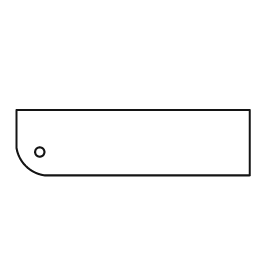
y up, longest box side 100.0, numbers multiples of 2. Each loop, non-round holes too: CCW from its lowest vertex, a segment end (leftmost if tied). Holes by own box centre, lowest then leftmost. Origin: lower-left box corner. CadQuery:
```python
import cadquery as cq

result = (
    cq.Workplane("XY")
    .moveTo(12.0, 0.0)
    .lineTo(100.0, 0.0)
    .lineTo(100.0, 28.0)
    .lineTo(0.0, 28.0)
    .lineTo(0.0, 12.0)
    .threePointArc((4.0, 4.0), (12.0, 0.0))
    .close()
    .moveTo(10.0, 10.0)
    .circle(2.0)
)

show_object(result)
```